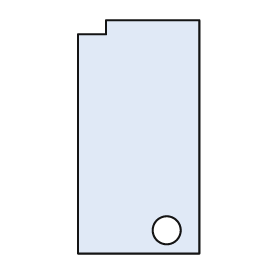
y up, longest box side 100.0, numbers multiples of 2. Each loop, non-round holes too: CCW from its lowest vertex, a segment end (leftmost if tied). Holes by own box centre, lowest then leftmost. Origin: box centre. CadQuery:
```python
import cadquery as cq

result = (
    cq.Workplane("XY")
    .moveTo(-26.0, -50.0)
    .lineTo(26.0, -50.0)
    .lineTo(26.0, 50.0)
    .lineTo(-14.0, 50.0)
    .lineTo(-14.0, 44.0)
    .lineTo(-26.0, 44.0)
    .close()
    .moveTo(12.0, -40.0)
    .circle(6.0)
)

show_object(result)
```